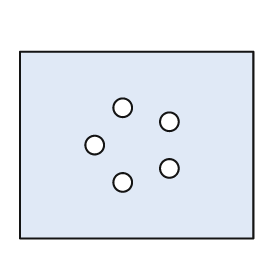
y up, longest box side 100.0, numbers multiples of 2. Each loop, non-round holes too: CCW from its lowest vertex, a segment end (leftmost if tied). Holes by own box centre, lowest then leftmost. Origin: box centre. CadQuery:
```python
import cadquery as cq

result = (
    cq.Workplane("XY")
    .moveTo(-50.0, -40.0)
    .lineTo(50.0, -40.0)
    .lineTo(50.0, 40.0)
    .lineTo(-50.0, 40.0)
    .close()
    .moveTo(-6.0, -16.0)
    .circle(4.0)
    .moveTo(14.0, -10.0)
    .circle(4.0)
    .moveTo(-18.0, 0.0)
    .circle(4.0)
    .moveTo(14.0, 10.0)
    .circle(4.0)
    .moveTo(-6.0, 16.0)
    .circle(4.0)
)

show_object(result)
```